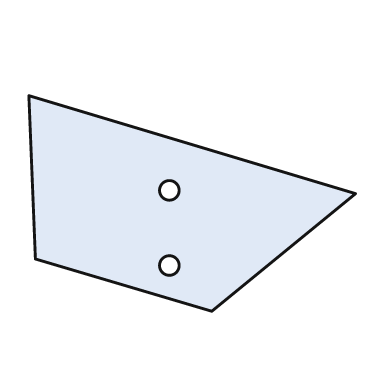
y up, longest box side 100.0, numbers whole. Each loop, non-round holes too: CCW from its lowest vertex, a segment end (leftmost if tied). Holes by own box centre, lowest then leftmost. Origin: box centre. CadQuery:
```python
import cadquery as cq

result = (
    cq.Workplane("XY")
    .moveTo(6.0, -33.0)
    .lineTo(50.0, 3.0)
    .lineTo(-50.0, 33.0)
    .lineTo(-48.0, -17.0)
    .close()
    .moveTo(-7.0, -19.0)
    .circle(3.0)
    .moveTo(-7.0, 4.0)
    .circle(3.0)
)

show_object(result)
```